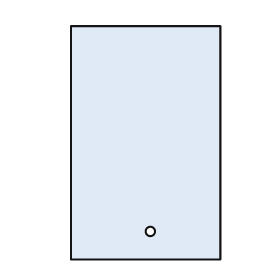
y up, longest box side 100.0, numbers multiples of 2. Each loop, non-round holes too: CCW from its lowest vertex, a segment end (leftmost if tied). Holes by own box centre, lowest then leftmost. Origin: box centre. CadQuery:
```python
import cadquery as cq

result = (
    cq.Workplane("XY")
    .moveTo(-32.0, -50.0)
    .lineTo(32.0, -50.0)
    .lineTo(32.0, 50.0)
    .lineTo(-32.0, 50.0)
    .close()
    .moveTo(2.0, -38.0)
    .circle(2.0)
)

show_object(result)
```